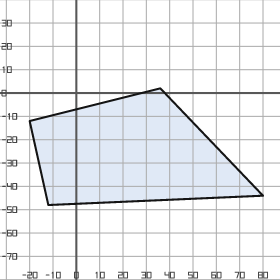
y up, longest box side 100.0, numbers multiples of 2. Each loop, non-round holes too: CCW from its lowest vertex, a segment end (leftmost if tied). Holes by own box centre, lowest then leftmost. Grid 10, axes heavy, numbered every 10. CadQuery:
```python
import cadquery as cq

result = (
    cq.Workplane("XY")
    .moveTo(-12.0, -48.0)
    .lineTo(80.0, -44.0)
    .lineTo(36.0, 2.0)
    .lineTo(-20.0, -12.0)
    .close()
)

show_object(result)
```